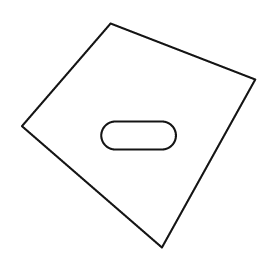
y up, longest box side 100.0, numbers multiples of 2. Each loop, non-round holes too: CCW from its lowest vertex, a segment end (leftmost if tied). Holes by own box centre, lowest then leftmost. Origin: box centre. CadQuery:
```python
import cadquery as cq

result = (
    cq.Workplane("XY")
    .moveTo(10.0, -48.0)
    .lineTo(50.0, 24.0)
    .lineTo(-12.0, 48.0)
    .lineTo(-50.0, 4.0)
    .close()
    .moveTo(-10.0, -6.0)
    .lineTo(10.0, -6.0)
    .threePointArc((16.0, 0.0), (10.0, 6.0))
    .lineTo(-10.0, 6.0)
    .threePointArc((-16.0, 0.0), (-10.0, -6.0))
    .close()
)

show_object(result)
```